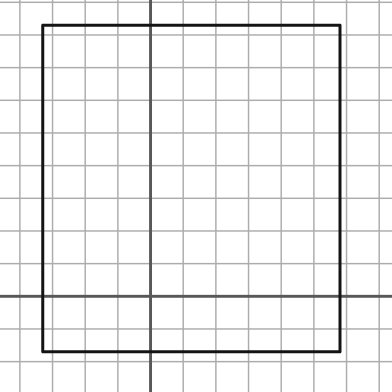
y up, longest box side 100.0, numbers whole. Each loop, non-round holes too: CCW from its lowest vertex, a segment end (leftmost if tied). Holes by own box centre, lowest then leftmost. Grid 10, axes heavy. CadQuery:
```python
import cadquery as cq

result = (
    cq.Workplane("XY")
    .moveTo(-33.0, -17.0)
    .lineTo(58.0, -17.0)
    .lineTo(58.0, 83.0)
    .lineTo(-33.0, 83.0)
    .close()
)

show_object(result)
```